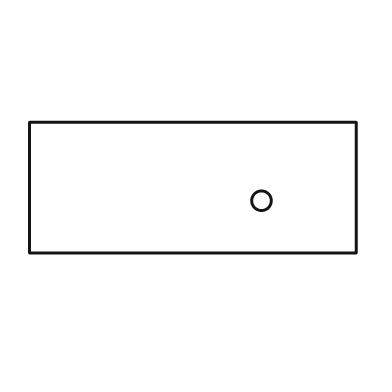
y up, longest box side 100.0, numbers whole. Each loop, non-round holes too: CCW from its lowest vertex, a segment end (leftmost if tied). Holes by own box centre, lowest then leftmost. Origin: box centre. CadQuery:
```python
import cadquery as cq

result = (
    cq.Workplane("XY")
    .moveTo(-50.0, -20.0)
    .lineTo(50.0, -20.0)
    .lineTo(50.0, 20.0)
    .lineTo(-50.0, 20.0)
    .close()
    .moveTo(21.0, -4.0)
    .circle(3.0)
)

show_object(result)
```